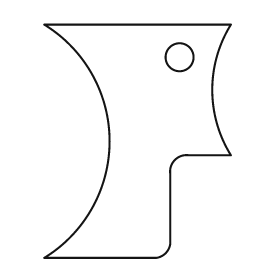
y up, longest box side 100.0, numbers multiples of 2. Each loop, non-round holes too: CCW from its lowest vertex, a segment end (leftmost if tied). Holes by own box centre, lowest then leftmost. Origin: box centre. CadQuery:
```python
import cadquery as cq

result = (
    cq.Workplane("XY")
    .moveTo(-40.0, -50.0)
    .lineTo(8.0, -50.0)
    .threePointArc((12.0, -48.0), (14.0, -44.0))
    .lineTo(14.0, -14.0)
    .threePointArc((16.0, -8.0), (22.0, -6.0))
    .lineTo(40.0, -6.0)
    .threePointArc((32.0, 22.0), (40.0, 50.0))
    .lineTo(-40.0, 50.0)
    .threePointArc((-12.0, 0.0), (-40.0, -50.0))
    .close()
    .moveTo(18.0, 36.0)
    .circle(6.0)
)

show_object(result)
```